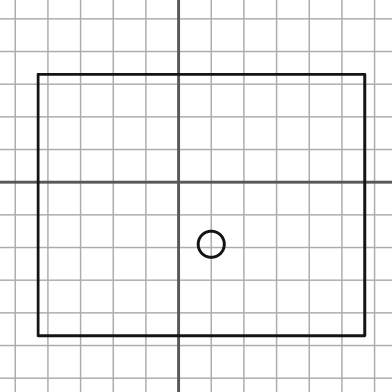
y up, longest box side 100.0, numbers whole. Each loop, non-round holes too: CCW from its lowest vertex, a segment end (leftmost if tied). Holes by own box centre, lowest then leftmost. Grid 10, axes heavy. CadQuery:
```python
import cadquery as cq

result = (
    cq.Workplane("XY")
    .moveTo(-43.0, -47.0)
    .lineTo(57.0, -47.0)
    .lineTo(57.0, 33.0)
    .lineTo(-43.0, 33.0)
    .close()
    .moveTo(10.0, -19.0)
    .circle(4.0)
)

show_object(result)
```